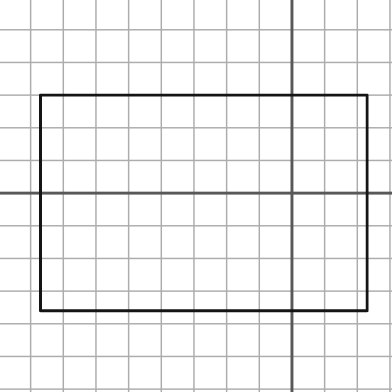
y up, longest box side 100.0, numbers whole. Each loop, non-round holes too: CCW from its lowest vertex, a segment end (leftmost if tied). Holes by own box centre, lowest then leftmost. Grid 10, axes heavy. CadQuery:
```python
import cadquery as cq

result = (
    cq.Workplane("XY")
    .moveTo(-77.0, -36.0)
    .lineTo(23.0, -36.0)
    .lineTo(23.0, 30.0)
    .lineTo(-77.0, 30.0)
    .close()
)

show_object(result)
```